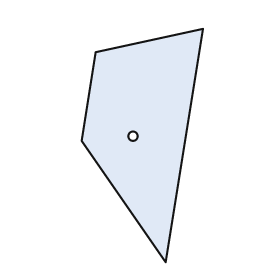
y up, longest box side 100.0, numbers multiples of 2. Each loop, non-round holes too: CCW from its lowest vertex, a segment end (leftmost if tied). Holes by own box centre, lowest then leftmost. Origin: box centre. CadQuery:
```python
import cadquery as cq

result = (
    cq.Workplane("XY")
    .moveTo(10.0, -50.0)
    .lineTo(26.0, 50.0)
    .lineTo(-20.0, 40.0)
    .lineTo(-26.0, 2.0)
    .close()
    .moveTo(-4.0, 4.0)
    .circle(2.0)
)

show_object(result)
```